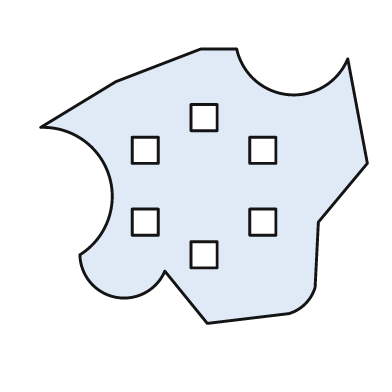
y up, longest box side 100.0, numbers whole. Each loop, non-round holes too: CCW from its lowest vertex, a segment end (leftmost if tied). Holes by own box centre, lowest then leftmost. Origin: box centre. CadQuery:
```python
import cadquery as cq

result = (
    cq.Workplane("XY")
    .moveTo(1.0, -42.0)
    .lineTo(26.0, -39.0)
    .threePointArc((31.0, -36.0), (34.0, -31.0))
    .lineTo(35.0, -11.0)
    .lineTo(50.0, 7.0)
    .lineTo(44.0, 39.0)
    .threePointArc((26.0, 28.0), (10.0, 42.0))
    .lineTo(-1.0, 42.0)
    .lineTo(-27.0, 32.0)
    .lineTo(-50.0, 18.0)
    .threePointArc((-29.0, 3.0), (-38.0, -21.0))
    .threePointArc((-27.0, -34.0), (-12.0, -26.0))
    .close()
    .moveTo(-4.0, -25.0)
    .lineTo(4.0, -25.0)
    .lineTo(4.0, -17.0)
    .lineTo(-4.0, -17.0)
    .close()
    .moveTo(-22.0, -15.0)
    .lineTo(-14.0, -15.0)
    .lineTo(-14.0, -7.0)
    .lineTo(-22.0, -7.0)
    .close()
    .moveTo(14.0, -15.0)
    .lineTo(22.0, -15.0)
    .lineTo(22.0, -7.0)
    .lineTo(14.0, -7.0)
    .close()
    .moveTo(-22.0, 7.0)
    .lineTo(-14.0, 7.0)
    .lineTo(-14.0, 15.0)
    .lineTo(-22.0, 15.0)
    .close()
    .moveTo(14.0, 7.0)
    .lineTo(22.0, 7.0)
    .lineTo(22.0, 15.0)
    .lineTo(14.0, 15.0)
    .close()
    .moveTo(-4.0, 17.0)
    .lineTo(4.0, 17.0)
    .lineTo(4.0, 25.0)
    .lineTo(-4.0, 25.0)
    .close()
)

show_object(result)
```